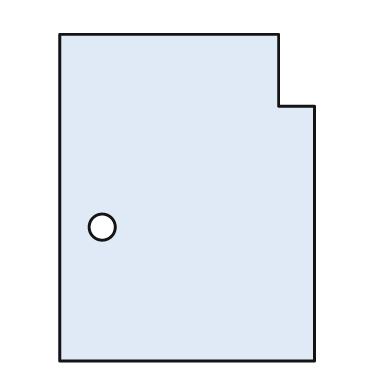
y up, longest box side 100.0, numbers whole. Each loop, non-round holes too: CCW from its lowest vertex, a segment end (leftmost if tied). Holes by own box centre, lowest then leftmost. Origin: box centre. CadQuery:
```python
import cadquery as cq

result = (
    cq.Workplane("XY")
    .moveTo(-39.0, -50.0)
    .lineTo(39.0, -50.0)
    .lineTo(39.0, 28.0)
    .lineTo(28.0, 28.0)
    .lineTo(28.0, 50.0)
    .lineTo(-39.0, 50.0)
    .close()
    .moveTo(-26.0, -9.0)
    .circle(4.0)
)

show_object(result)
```